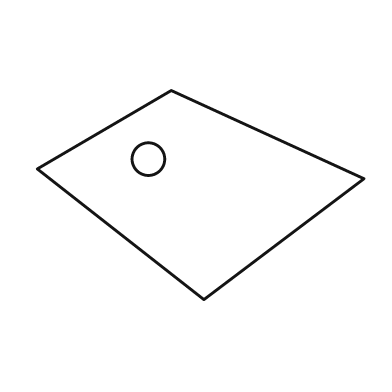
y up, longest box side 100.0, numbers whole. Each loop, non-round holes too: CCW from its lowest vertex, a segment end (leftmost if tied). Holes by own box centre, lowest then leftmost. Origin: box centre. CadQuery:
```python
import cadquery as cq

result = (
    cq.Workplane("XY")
    .moveTo(1.0, -32.0)
    .lineTo(50.0, 5.0)
    .lineTo(-9.0, 32.0)
    .lineTo(-50.0, 8.0)
    .close()
    .moveTo(-16.0, 11.0)
    .circle(5.0)
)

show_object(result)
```